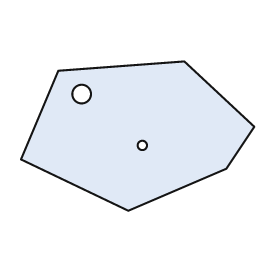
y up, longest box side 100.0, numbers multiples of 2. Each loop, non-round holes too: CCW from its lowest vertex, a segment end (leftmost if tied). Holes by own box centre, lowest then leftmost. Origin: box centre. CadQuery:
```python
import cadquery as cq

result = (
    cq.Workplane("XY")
    .moveTo(-4.0, -32.0)
    .lineTo(38.0, -14.0)
    .lineTo(50.0, 4.0)
    .lineTo(20.0, 32.0)
    .lineTo(-34.0, 28.0)
    .lineTo(-50.0, -10.0)
    .close()
    .moveTo(2.0, -4.0)
    .circle(2.0)
    .moveTo(-24.0, 18.0)
    .circle(4.0)
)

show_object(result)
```